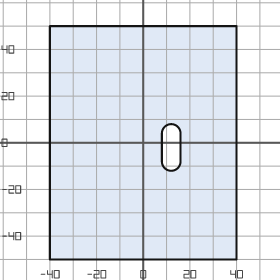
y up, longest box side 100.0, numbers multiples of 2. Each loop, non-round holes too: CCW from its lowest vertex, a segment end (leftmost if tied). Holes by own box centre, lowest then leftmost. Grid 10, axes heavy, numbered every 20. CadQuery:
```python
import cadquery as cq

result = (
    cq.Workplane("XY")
    .moveTo(-40.0, -50.0)
    .lineTo(40.0, -50.0)
    .lineTo(40.0, 50.0)
    .lineTo(-40.0, 50.0)
    .close()
    .moveTo(8.0, -8.0)
    .threePointArc((12.0, -12.0), (16.0, -8.0))
    .lineTo(16.0, 4.0)
    .threePointArc((12.0, 8.0), (8.0, 4.0))
    .close()
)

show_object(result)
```